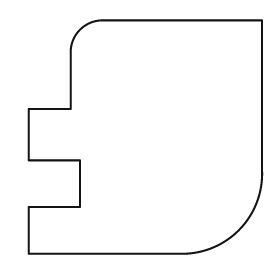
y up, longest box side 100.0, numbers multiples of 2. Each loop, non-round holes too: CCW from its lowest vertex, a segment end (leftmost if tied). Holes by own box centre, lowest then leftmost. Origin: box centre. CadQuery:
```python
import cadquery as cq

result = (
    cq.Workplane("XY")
    .moveTo(-50.0, -50.0)
    .lineTo(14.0, -50.0)
    .threePointArc((40.0, -40.0), (50.0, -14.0))
    .lineTo(50.0, 50.0)
    .lineTo(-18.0, 50.0)
    .threePointArc((-28.0, 46.0), (-32.0, 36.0))
    .lineTo(-32.0, 12.0)
    .lineTo(-50.0, 12.0)
    .lineTo(-50.0, -10.0)
    .lineTo(-28.0, -10.0)
    .lineTo(-28.0, -30.0)
    .lineTo(-50.0, -30.0)
    .close()
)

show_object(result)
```